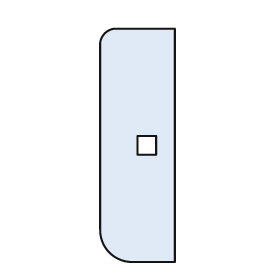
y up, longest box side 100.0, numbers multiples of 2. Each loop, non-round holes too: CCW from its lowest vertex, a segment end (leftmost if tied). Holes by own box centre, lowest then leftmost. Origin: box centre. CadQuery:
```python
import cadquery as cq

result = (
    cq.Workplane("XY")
    .moveTo(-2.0, -50.0)
    .lineTo(16.0, -50.0)
    .lineTo(16.0, 50.0)
    .lineTo(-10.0, 50.0)
    .threePointArc((-14.0, 48.0), (-16.0, 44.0))
    .lineTo(-16.0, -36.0)
    .threePointArc((-12.0, -46.0), (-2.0, -50.0))
    .close()
    .moveTo(0.0, -4.0)
    .lineTo(8.0, -4.0)
    .lineTo(8.0, 4.0)
    .lineTo(0.0, 4.0)
    .close()
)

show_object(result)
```